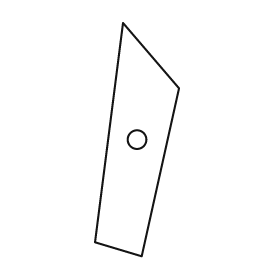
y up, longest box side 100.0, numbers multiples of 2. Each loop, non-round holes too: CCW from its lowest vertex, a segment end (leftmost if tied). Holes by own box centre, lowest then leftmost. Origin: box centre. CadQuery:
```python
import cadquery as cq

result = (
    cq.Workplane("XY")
    .moveTo(2.0, -50.0)
    .lineTo(18.0, 22.0)
    .lineTo(-6.0, 50.0)
    .lineTo(-18.0, -44.0)
    .close()
    .moveTo(0.0, 0.0)
    .circle(4.0)
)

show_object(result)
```